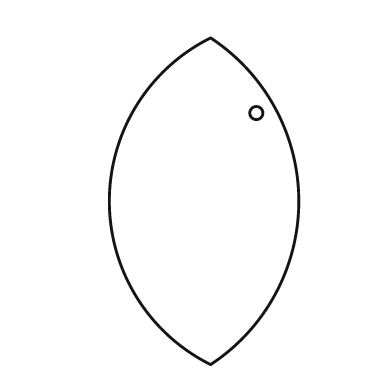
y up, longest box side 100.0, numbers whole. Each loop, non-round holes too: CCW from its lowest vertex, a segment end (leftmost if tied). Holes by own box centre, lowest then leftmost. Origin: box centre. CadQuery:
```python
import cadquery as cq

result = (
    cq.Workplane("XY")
    .moveTo(2.0, -50.0)
    .threePointArc((29.0, 0.0), (2.0, 50.0))
    .threePointArc((-29.0, 0.0), (2.0, -50.0))
    .close()
    .moveTo(16.0, 27.0)
    .circle(2.0)
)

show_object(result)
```